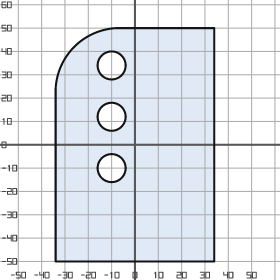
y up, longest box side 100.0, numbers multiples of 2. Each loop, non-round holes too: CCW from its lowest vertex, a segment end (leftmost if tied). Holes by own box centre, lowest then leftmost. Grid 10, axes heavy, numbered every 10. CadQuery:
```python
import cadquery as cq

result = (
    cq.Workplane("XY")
    .moveTo(-34.0, -50.0)
    .lineTo(34.0, -50.0)
    .lineTo(34.0, 50.0)
    .lineTo(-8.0, 50.0)
    .threePointArc((-26.0, 42.0), (-34.0, 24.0))
    .close()
    .moveTo(-10.0, -10.0)
    .circle(6.0)
    .moveTo(-10.0, 12.0)
    .circle(6.0)
    .moveTo(-10.0, 34.0)
    .circle(6.0)
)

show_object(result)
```